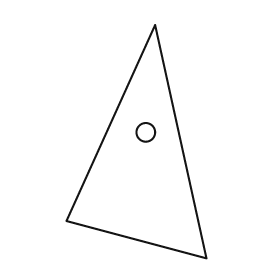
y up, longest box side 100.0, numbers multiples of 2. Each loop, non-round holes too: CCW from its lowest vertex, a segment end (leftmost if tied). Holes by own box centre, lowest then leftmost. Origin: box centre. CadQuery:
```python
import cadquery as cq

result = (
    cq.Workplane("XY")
    .moveTo(30.0, -50.0)
    .lineTo(8.0, 50.0)
    .lineTo(-30.0, -34.0)
    .close()
    .moveTo(4.0, 4.0)
    .circle(4.0)
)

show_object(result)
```